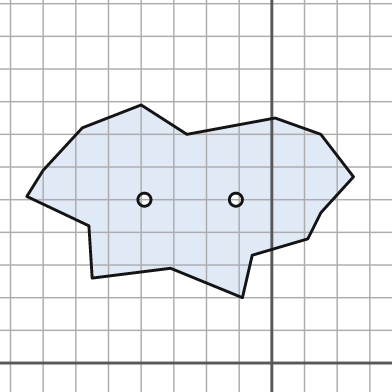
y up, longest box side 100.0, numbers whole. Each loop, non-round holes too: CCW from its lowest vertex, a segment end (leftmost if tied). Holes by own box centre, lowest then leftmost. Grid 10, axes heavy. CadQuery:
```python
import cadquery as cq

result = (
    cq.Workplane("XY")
    .moveTo(-9.0, 20.0)
    .lineTo(-6.0, 33.0)
    .lineTo(11.0, 38.0)
    .lineTo(15.0, 46.0)
    .lineTo(25.0, 57.0)
    .lineTo(15.0, 70.0)
    .lineTo(1.0, 75.0)
    .lineTo(-26.0, 70.0)
    .lineTo(-40.0, 79.0)
    .lineTo(-58.0, 72.0)
    .lineTo(-70.0, 59.0)
    .lineTo(-75.0, 51.0)
    .lineTo(-56.0, 42.0)
    .lineTo(-55.0, 26.0)
    .lineTo(-31.0, 29.0)
    .close()
    .moveTo(-39.0, 50.0)
    .circle(2.0)
    .moveTo(-11.0, 50.0)
    .circle(2.0)
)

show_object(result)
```